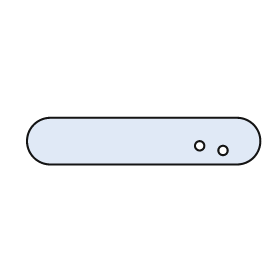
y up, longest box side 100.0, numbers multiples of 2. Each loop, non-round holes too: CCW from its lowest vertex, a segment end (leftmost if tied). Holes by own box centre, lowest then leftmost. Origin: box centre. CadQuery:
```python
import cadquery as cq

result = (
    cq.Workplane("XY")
    .moveTo(-40.0, -10.0)
    .lineTo(40.0, -10.0)
    .threePointArc((50.0, 0.0), (40.0, 10.0))
    .lineTo(-40.0, 10.0)
    .threePointArc((-50.0, 0.0), (-40.0, -10.0))
    .close()
    .moveTo(34.0, -4.0)
    .circle(2.0)
    .moveTo(24.0, -2.0)
    .circle(2.0)
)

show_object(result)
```